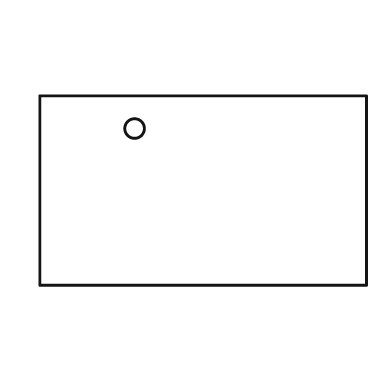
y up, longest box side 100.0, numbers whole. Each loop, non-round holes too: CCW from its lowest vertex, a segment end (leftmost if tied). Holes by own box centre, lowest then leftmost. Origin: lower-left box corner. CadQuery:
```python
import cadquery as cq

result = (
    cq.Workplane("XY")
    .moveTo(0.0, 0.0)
    .lineTo(100.0, 0.0)
    .lineTo(100.0, 58.0)
    .lineTo(0.0, 58.0)
    .close()
    .moveTo(29.0, 48.0)
    .circle(3.0)
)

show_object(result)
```